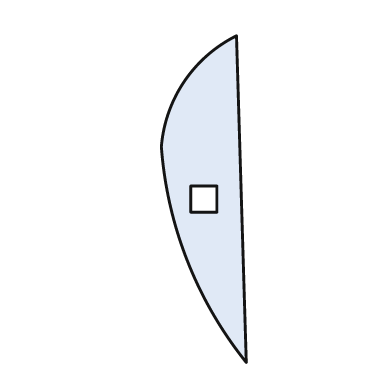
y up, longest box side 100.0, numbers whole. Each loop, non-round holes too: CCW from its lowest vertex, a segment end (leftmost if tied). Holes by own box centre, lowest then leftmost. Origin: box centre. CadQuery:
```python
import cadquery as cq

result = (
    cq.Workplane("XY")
    .moveTo(13.0, -50.0)
    .lineTo(10.0, 50.0)
    .threePointArc((-6.0, 36.0), (-13.0, 16.0))
    .threePointArc((-5.0, -19.0), (13.0, -50.0))
    .close()
    .moveTo(-4.0, -4.0)
    .lineTo(4.0, -4.0)
    .lineTo(4.0, 4.0)
    .lineTo(-4.0, 4.0)
    .close()
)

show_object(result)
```